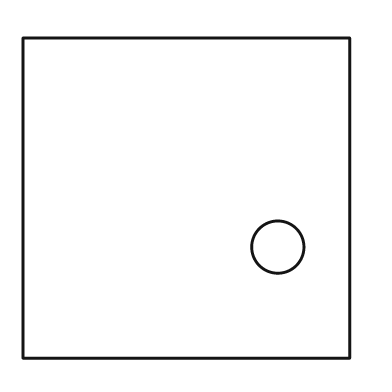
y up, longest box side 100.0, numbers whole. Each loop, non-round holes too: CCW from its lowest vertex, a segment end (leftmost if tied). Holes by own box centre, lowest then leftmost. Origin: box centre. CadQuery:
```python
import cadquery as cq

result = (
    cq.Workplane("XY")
    .moveTo(-50.0, -49.0)
    .lineTo(50.0, -49.0)
    .lineTo(50.0, 49.0)
    .lineTo(-50.0, 49.0)
    .close()
    .moveTo(28.0, -15.0)
    .circle(8.0)
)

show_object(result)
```